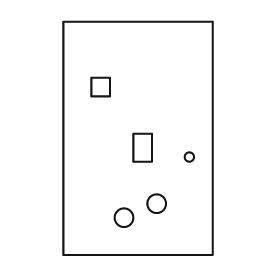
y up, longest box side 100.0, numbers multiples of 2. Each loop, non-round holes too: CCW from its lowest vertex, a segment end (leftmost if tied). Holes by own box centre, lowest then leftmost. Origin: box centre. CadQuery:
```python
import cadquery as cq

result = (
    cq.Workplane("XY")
    .moveTo(-32.0, -50.0)
    .lineTo(32.0, -50.0)
    .lineTo(32.0, 50.0)
    .lineTo(-32.0, 50.0)
    .close()
    .moveTo(-6.0, -34.0)
    .circle(4.0)
    .moveTo(8.0, -28.0)
    .circle(4.0)
    .moveTo(22.0, -8.0)
    .circle(2.0)
    .moveTo(-2.0, -10.0)
    .lineTo(6.0, -10.0)
    .lineTo(6.0, 2.0)
    .lineTo(-2.0, 2.0)
    .close()
    .moveTo(-20.0, 18.0)
    .lineTo(-12.0, 18.0)
    .lineTo(-12.0, 26.0)
    .lineTo(-20.0, 26.0)
    .close()
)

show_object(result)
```